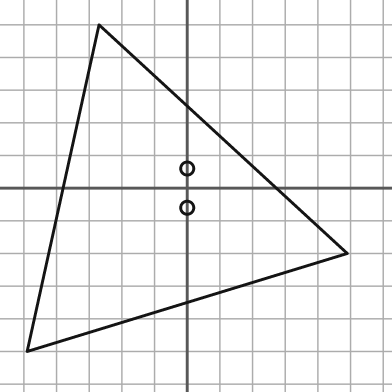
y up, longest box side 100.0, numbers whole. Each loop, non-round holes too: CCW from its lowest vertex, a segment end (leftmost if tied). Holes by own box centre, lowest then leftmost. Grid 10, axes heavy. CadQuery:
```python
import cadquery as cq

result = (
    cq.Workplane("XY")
    .moveTo(-49.0, -50.0)
    .lineTo(49.0, -20.0)
    .lineTo(-27.0, 50.0)
    .close()
    .moveTo(0.0, -6.0)
    .circle(2.0)
    .moveTo(0.0, 6.0)
    .circle(2.0)
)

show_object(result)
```